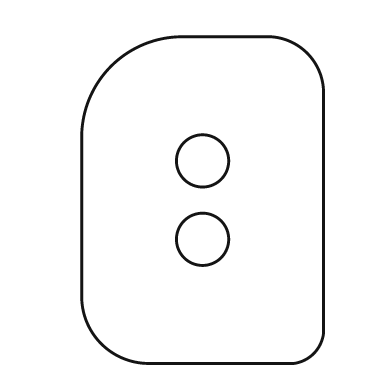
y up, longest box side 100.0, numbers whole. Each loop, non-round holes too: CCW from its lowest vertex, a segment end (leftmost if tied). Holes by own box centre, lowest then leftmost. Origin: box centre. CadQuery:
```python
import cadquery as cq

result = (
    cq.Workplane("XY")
    .moveTo(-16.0, -50.0)
    .lineTo(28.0, -50.0)
    .threePointArc((34.0, -47.0), (37.0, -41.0))
    .lineTo(37.0, 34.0)
    .threePointArc((32.0, 45.0), (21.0, 50.0))
    .lineTo(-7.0, 50.0)
    .threePointArc((-28.0, 41.0), (-37.0, 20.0))
    .lineTo(-37.0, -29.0)
    .threePointArc((-31.0, -44.0), (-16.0, -50.0))
    .close()
    .moveTo(0.0, -12.0)
    .circle(8.0)
    .moveTo(0.0, 12.0)
    .circle(8.0)
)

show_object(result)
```